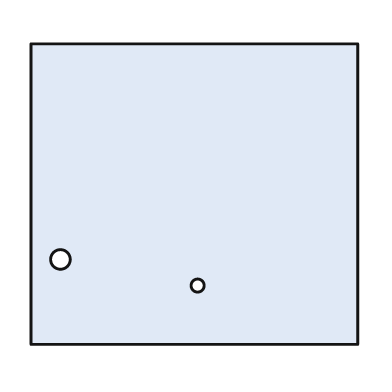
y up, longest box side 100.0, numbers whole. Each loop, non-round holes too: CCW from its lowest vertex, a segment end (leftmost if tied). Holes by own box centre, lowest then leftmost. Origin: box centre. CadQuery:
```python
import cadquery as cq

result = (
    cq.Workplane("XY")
    .moveTo(-50.0, -46.0)
    .lineTo(50.0, -46.0)
    .lineTo(50.0, 46.0)
    .lineTo(-50.0, 46.0)
    .close()
    .moveTo(1.0, -28.0)
    .circle(2.0)
    .moveTo(-41.0, -20.0)
    .circle(3.0)
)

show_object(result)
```